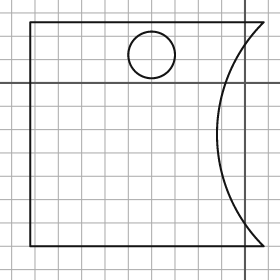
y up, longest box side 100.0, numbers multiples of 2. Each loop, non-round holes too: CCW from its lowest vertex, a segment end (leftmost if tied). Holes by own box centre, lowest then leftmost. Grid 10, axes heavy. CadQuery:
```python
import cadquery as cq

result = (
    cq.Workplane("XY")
    .moveTo(-92.0, -70.0)
    .lineTo(8.0, -70.0)
    .threePointArc((-12.0, -22.0), (8.0, 26.0))
    .lineTo(-92.0, 26.0)
    .close()
    .moveTo(-40.0, 12.0)
    .circle(10.0)
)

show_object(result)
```